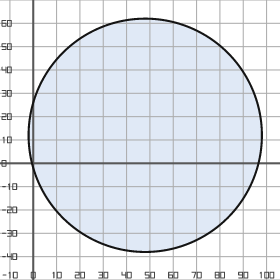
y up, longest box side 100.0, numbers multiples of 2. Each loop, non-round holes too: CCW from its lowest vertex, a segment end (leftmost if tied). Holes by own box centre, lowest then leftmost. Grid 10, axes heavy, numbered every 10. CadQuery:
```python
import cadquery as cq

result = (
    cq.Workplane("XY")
    .moveTo(48.0, 12.0)
    .circle(50.0)
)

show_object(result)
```